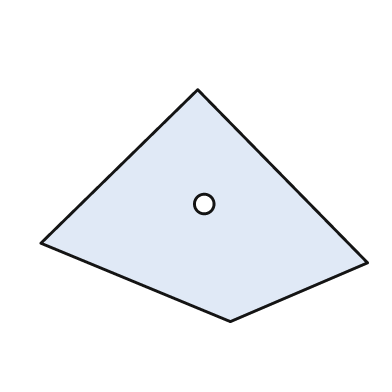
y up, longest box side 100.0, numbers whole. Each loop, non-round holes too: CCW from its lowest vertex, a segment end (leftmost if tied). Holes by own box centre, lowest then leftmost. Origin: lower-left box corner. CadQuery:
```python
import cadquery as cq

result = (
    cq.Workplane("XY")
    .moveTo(58.0, 0.0)
    .lineTo(100.0, 18.0)
    .lineTo(48.0, 71.0)
    .lineTo(0.0, 24.0)
    .close()
    .moveTo(50.0, 36.0)
    .circle(3.0)
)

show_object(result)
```